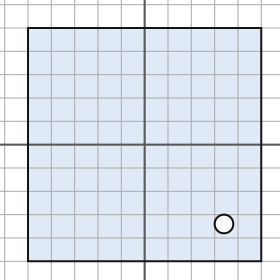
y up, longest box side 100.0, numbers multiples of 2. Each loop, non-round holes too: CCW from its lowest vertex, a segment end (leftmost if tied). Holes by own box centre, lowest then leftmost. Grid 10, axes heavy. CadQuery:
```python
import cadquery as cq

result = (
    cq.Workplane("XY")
    .moveTo(-50.0, -50.0)
    .lineTo(50.0, -50.0)
    .lineTo(50.0, 50.0)
    .lineTo(-50.0, 50.0)
    .close()
    .moveTo(34.0, -34.0)
    .circle(4.0)
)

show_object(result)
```